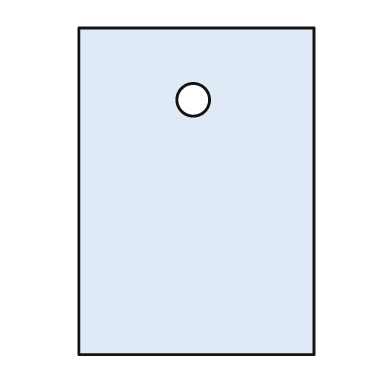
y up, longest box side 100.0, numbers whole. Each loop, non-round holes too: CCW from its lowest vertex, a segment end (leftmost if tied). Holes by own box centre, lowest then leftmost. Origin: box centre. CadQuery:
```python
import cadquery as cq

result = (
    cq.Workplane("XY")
    .moveTo(-36.0, -50.0)
    .lineTo(36.0, -50.0)
    .lineTo(36.0, 50.0)
    .lineTo(-36.0, 50.0)
    .close()
    .moveTo(-1.0, 28.0)
    .circle(5.0)
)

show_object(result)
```